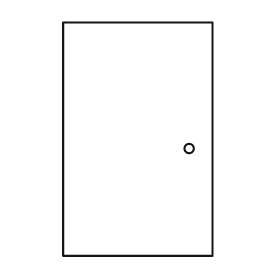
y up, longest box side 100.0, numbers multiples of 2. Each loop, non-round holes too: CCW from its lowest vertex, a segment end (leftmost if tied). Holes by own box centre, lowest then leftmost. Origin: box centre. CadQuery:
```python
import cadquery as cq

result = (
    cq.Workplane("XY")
    .moveTo(-32.0, -50.0)
    .lineTo(32.0, -50.0)
    .lineTo(32.0, 50.0)
    .lineTo(-32.0, 50.0)
    .close()
    .moveTo(22.0, -4.0)
    .circle(2.0)
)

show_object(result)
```